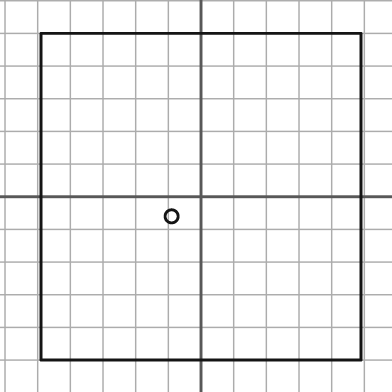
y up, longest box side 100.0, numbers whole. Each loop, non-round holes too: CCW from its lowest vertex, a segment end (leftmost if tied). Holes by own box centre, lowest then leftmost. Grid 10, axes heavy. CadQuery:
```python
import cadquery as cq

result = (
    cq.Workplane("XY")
    .moveTo(-49.0, -50.0)
    .lineTo(49.0, -50.0)
    .lineTo(49.0, 50.0)
    .lineTo(-49.0, 50.0)
    .close()
    .moveTo(-9.0, -6.0)
    .circle(2.0)
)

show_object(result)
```